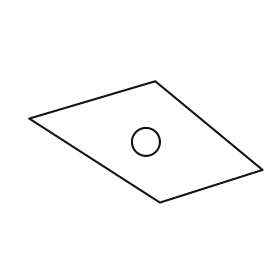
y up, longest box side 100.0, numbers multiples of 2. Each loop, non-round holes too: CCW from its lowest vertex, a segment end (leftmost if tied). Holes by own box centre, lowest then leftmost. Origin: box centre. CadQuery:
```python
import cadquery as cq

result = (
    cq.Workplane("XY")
    .moveTo(6.0, -26.0)
    .lineTo(50.0, -12.0)
    .lineTo(4.0, 26.0)
    .lineTo(-50.0, 10.0)
    .close()
    .moveTo(0.0, 0.0)
    .circle(6.0)
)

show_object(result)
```